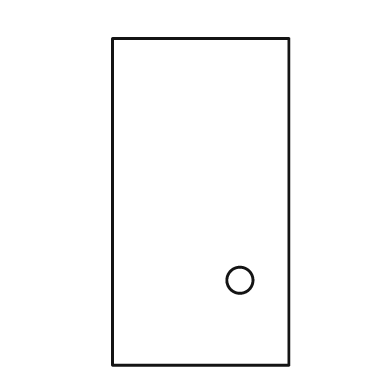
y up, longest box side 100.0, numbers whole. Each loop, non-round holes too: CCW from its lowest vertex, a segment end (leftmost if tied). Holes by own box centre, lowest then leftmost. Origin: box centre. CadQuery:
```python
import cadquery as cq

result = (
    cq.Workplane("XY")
    .moveTo(-27.0, -50.0)
    .lineTo(27.0, -50.0)
    .lineTo(27.0, 50.0)
    .lineTo(-27.0, 50.0)
    .close()
    .moveTo(12.0, -24.0)
    .circle(4.0)
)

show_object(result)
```